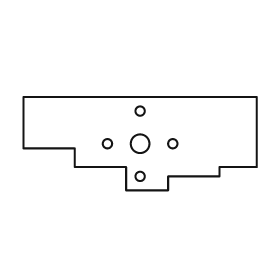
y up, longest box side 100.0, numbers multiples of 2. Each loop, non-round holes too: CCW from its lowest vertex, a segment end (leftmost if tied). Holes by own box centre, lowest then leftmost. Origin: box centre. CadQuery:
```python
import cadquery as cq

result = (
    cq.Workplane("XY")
    .moveTo(-6.0, -20.0)
    .lineTo(12.0, -20.0)
    .lineTo(12.0, -14.0)
    .lineTo(34.0, -14.0)
    .lineTo(34.0, -10.0)
    .lineTo(50.0, -10.0)
    .lineTo(50.0, 20.0)
    .lineTo(-50.0, 20.0)
    .lineTo(-50.0, -2.0)
    .lineTo(-28.0, -2.0)
    .lineTo(-28.0, -10.0)
    .lineTo(-6.0, -10.0)
    .close()
    .moveTo(0.0, -14.0)
    .circle(2.0)
    .moveTo(-14.0, 0.0)
    .circle(2.0)
    .moveTo(0.0, 0.0)
    .circle(4.0)
    .moveTo(14.0, 0.0)
    .circle(2.0)
    .moveTo(0.0, 14.0)
    .circle(2.0)
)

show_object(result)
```